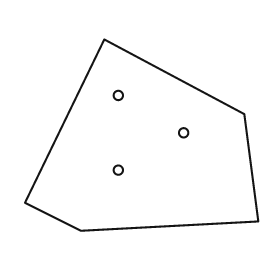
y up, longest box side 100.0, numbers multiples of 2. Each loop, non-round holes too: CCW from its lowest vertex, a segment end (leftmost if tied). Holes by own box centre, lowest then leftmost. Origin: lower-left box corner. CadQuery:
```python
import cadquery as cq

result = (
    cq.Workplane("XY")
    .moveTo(24.0, 0.0)
    .lineTo(100.0, 4.0)
    .lineTo(94.0, 50.0)
    .lineTo(34.0, 82.0)
    .lineTo(0.0, 12.0)
    .close()
    .moveTo(40.0, 26.0)
    .circle(2.0)
    .moveTo(68.0, 42.0)
    .circle(2.0)
    .moveTo(40.0, 58.0)
    .circle(2.0)
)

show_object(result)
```